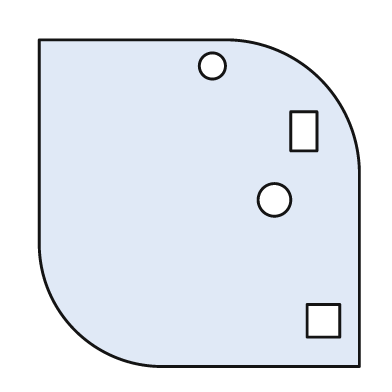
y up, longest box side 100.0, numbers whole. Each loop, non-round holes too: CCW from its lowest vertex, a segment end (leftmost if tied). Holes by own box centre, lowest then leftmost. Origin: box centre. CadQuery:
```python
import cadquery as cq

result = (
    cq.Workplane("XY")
    .moveTo(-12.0, -50.0)
    .lineTo(49.0, -50.0)
    .lineTo(49.0, 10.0)
    .threePointArc((37.0, 38.0), (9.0, 50.0))
    .lineTo(-49.0, 50.0)
    .lineTo(-49.0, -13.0)
    .threePointArc((-38.0, -39.0), (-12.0, -50.0))
    .close()
    .moveTo(33.0, -41.0)
    .lineTo(43.0, -41.0)
    .lineTo(43.0, -31.0)
    .lineTo(33.0, -31.0)
    .close()
    .moveTo(23.0, 1.0)
    .circle(5.0)
    .moveTo(28.0, 16.0)
    .lineTo(36.0, 16.0)
    .lineTo(36.0, 28.0)
    .lineTo(28.0, 28.0)
    .close()
    .moveTo(4.0, 42.0)
    .circle(4.0)
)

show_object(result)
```